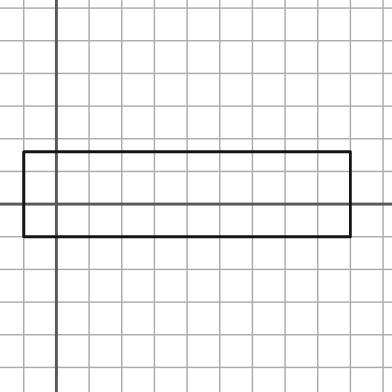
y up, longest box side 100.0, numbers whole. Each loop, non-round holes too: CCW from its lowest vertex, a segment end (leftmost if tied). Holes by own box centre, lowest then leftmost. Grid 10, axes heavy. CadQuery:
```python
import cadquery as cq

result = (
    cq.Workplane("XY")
    .moveTo(-10.0, -10.0)
    .lineTo(90.0, -10.0)
    .lineTo(90.0, 16.0)
    .lineTo(-10.0, 16.0)
    .close()
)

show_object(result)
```